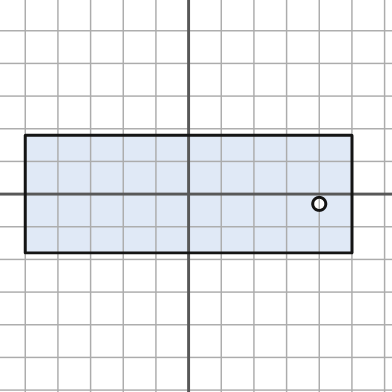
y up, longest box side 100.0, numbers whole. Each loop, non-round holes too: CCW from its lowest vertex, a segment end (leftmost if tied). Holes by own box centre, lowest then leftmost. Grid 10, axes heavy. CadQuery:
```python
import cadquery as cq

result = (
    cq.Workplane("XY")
    .moveTo(-50.0, -18.0)
    .lineTo(50.0, -18.0)
    .lineTo(50.0, 18.0)
    .lineTo(-50.0, 18.0)
    .close()
    .moveTo(40.0, -3.0)
    .circle(2.0)
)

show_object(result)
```